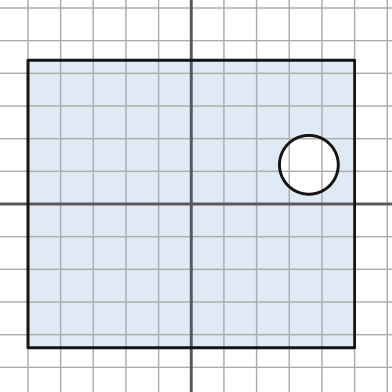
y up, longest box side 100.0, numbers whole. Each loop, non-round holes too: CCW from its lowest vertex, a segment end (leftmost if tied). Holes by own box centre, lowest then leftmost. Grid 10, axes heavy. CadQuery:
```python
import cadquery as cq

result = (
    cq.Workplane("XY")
    .moveTo(-50.0, -44.0)
    .lineTo(50.0, -44.0)
    .lineTo(50.0, 44.0)
    .lineTo(-50.0, 44.0)
    .close()
    .moveTo(36.0, 12.0)
    .circle(9.0)
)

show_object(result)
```